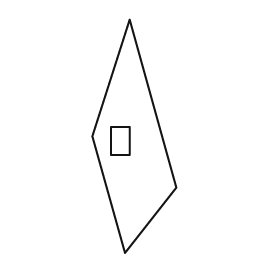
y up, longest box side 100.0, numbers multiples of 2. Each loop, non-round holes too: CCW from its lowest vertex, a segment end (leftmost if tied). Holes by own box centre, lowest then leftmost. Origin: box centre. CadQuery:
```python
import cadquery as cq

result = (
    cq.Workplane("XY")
    .moveTo(-4.0, -50.0)
    .lineTo(18.0, -22.0)
    .lineTo(-2.0, 50.0)
    .lineTo(-18.0, 0.0)
    .close()
    .moveTo(-10.0, -8.0)
    .lineTo(-2.0, -8.0)
    .lineTo(-2.0, 4.0)
    .lineTo(-10.0, 4.0)
    .close()
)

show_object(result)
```